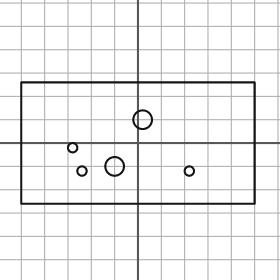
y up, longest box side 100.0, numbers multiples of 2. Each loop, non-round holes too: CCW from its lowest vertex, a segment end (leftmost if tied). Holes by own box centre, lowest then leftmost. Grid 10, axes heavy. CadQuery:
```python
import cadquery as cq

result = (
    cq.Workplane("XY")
    .moveTo(-50.0, -26.0)
    .lineTo(50.0, -26.0)
    .lineTo(50.0, 26.0)
    .lineTo(-50.0, 26.0)
    .close()
    .moveTo(-24.0, -12.0)
    .circle(2.0)
    .moveTo(22.0, -12.0)
    .circle(2.0)
    .moveTo(-10.0, -10.0)
    .circle(4.0)
    .moveTo(-28.0, -2.0)
    .circle(2.0)
    .moveTo(2.0, 10.0)
    .circle(4.0)
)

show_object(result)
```